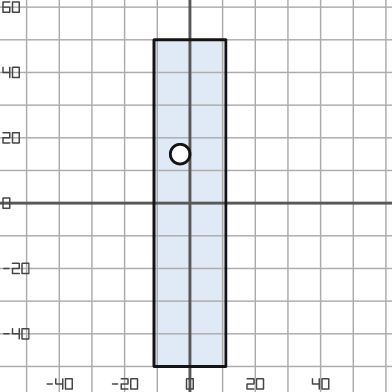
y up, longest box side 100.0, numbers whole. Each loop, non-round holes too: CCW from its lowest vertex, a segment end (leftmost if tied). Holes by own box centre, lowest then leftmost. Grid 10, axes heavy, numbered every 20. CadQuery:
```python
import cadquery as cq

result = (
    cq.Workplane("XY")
    .moveTo(-11.0, -50.0)
    .lineTo(11.0, -50.0)
    .lineTo(11.0, 50.0)
    .lineTo(-11.0, 50.0)
    .close()
    .moveTo(-3.0, 15.0)
    .circle(3.0)
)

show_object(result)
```